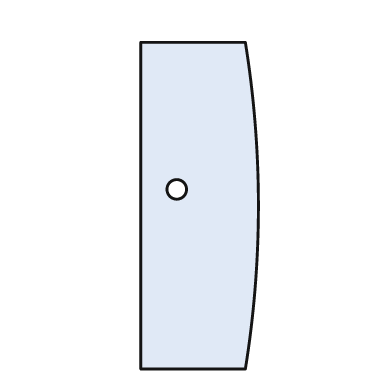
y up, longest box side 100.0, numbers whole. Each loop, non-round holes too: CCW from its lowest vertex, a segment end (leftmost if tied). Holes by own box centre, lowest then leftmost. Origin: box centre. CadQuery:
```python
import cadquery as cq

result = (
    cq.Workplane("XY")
    .moveTo(-18.0, -50.0)
    .lineTo(14.0, -50.0)
    .threePointArc((18.0, 0.0), (14.0, 50.0))
    .lineTo(-18.0, 50.0)
    .close()
    .moveTo(-7.0, 5.0)
    .circle(3.0)
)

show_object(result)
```